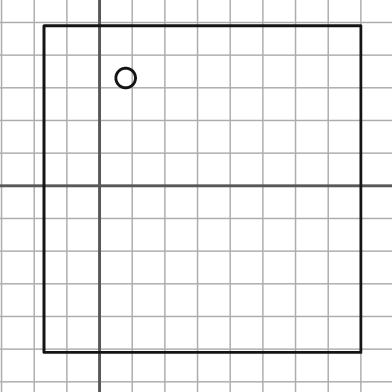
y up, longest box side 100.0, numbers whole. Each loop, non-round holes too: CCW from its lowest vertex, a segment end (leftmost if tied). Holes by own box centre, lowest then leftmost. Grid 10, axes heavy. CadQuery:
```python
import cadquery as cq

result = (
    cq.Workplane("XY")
    .moveTo(-17.0, -51.0)
    .lineTo(80.0, -51.0)
    .lineTo(80.0, 49.0)
    .lineTo(-17.0, 49.0)
    .close()
    .moveTo(8.0, 33.0)
    .circle(3.0)
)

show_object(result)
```